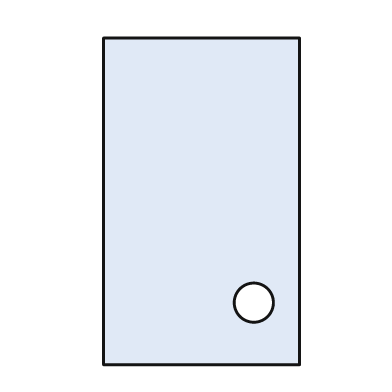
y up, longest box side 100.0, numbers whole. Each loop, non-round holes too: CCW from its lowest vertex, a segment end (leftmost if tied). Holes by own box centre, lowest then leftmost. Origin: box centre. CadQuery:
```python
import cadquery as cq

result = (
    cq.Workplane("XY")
    .moveTo(-30.0, -50.0)
    .lineTo(30.0, -50.0)
    .lineTo(30.0, 50.0)
    .lineTo(-30.0, 50.0)
    .close()
    .moveTo(16.0, -31.0)
    .circle(6.0)
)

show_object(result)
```